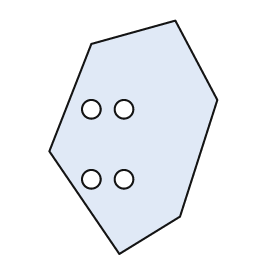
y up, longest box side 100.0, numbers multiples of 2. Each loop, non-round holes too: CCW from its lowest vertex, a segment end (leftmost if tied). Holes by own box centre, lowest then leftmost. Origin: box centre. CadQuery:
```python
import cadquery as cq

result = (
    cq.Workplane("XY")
    .moveTo(-6.0, -50.0)
    .lineTo(20.0, -34.0)
    .lineTo(36.0, 16.0)
    .lineTo(18.0, 50.0)
    .lineTo(-18.0, 40.0)
    .lineTo(-36.0, -6.0)
    .close()
    .moveTo(-18.0, -18.0)
    .circle(4.0)
    .moveTo(-4.0, -18.0)
    .circle(4.0)
    .moveTo(-18.0, 12.0)
    .circle(4.0)
    .moveTo(-4.0, 12.0)
    .circle(4.0)
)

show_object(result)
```